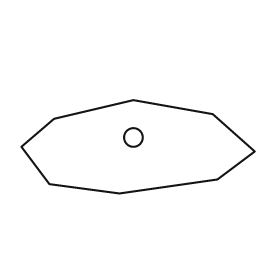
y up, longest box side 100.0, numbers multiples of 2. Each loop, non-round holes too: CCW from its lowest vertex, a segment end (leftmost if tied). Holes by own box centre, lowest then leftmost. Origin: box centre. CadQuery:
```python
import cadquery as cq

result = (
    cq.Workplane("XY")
    .moveTo(-8.0, -20.0)
    .lineTo(34.0, -14.0)
    .lineTo(50.0, -2.0)
    .lineTo(32.0, 14.0)
    .lineTo(-2.0, 20.0)
    .lineTo(-36.0, 12.0)
    .lineTo(-50.0, 0.0)
    .lineTo(-38.0, -16.0)
    .close()
    .moveTo(-2.0, 4.0)
    .circle(4.0)
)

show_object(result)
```